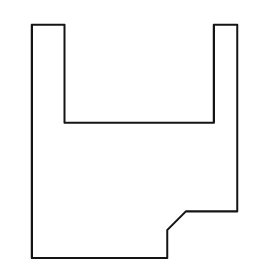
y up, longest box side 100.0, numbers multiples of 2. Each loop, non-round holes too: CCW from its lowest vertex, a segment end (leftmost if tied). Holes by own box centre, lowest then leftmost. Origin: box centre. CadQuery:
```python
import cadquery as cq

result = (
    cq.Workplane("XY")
    .moveTo(-44.0, -50.0)
    .lineTo(14.0, -50.0)
    .lineTo(14.0, -38.0)
    .lineTo(22.0, -30.0)
    .lineTo(44.0, -30.0)
    .lineTo(44.0, 50.0)
    .lineTo(34.0, 50.0)
    .lineTo(34.0, 8.0)
    .lineTo(-30.0, 8.0)
    .lineTo(-30.0, 50.0)
    .lineTo(-44.0, 50.0)
    .close()
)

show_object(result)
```